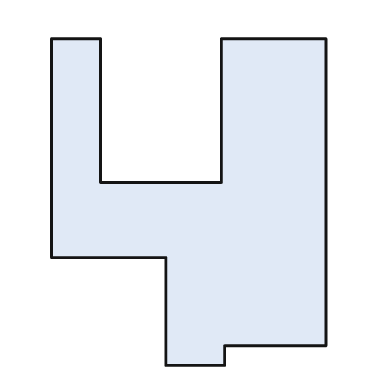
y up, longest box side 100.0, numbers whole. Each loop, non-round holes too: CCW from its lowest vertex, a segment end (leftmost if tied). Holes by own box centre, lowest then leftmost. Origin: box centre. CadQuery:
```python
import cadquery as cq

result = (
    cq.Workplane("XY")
    .moveTo(-7.0, -50.0)
    .lineTo(11.0, -50.0)
    .lineTo(11.0, -44.0)
    .lineTo(42.0, -44.0)
    .lineTo(42.0, 50.0)
    .lineTo(10.0, 50.0)
    .lineTo(10.0, 6.0)
    .lineTo(-27.0, 6.0)
    .lineTo(-27.0, 50.0)
    .lineTo(-42.0, 50.0)
    .lineTo(-42.0, -17.0)
    .lineTo(-7.0, -17.0)
    .close()
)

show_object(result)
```